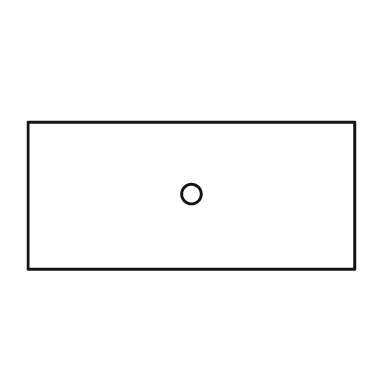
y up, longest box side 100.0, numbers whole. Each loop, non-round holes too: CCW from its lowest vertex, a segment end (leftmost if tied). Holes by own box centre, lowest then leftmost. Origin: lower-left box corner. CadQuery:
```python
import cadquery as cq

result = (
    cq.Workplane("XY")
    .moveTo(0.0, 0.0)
    .lineTo(100.0, 0.0)
    .lineTo(100.0, 45.0)
    .lineTo(0.0, 45.0)
    .close()
    .moveTo(50.0, 23.0)
    .circle(3.0)
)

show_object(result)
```